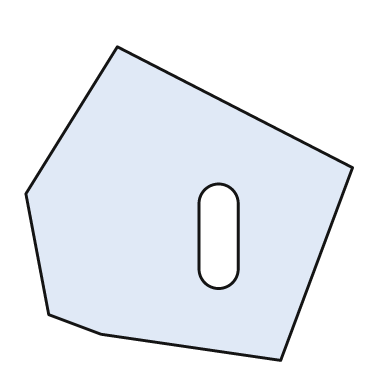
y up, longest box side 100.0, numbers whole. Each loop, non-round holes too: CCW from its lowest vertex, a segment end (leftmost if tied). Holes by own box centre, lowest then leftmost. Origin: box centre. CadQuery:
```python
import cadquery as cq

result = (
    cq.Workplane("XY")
    .moveTo(28.0, -48.0)
    .lineTo(50.0, 11.0)
    .lineTo(-22.0, 48.0)
    .lineTo(-50.0, 3.0)
    .lineTo(-43.0, -34.0)
    .lineTo(-27.0, -40.0)
    .close()
    .moveTo(3.0, -20.0)
    .threePointArc((9.0, -26.0), (15.0, -20.0))
    .lineTo(15.0, 0.0)
    .threePointArc((9.0, 6.0), (3.0, 0.0))
    .close()
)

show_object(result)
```